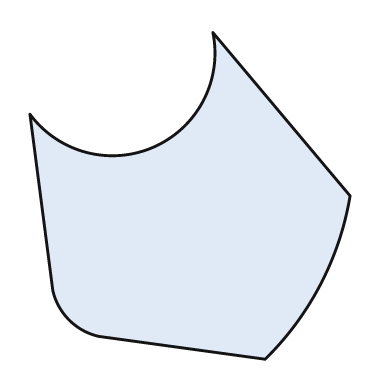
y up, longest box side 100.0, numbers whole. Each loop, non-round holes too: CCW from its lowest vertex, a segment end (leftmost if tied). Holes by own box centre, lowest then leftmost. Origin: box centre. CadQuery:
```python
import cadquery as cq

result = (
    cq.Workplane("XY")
    .moveTo(23.0, -50.0)
    .threePointArc((40.0, -27.0), (49.0, 0.0))
    .lineTo(7.0, 50.0)
    .threePointArc((-11.0, 15.0), (-49.0, 25.0))
    .lineTo(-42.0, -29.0)
    .threePointArc((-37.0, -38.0), (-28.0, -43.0))
    .close()
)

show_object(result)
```